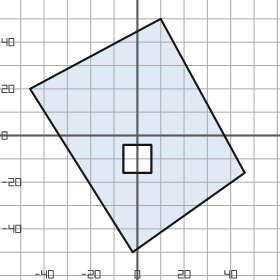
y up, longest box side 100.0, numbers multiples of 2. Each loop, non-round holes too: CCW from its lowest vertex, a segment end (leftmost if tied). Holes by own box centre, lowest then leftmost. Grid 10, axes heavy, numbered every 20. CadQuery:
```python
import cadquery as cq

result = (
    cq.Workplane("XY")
    .moveTo(-2.0, -50.0)
    .lineTo(46.0, -16.0)
    .lineTo(10.0, 50.0)
    .lineTo(-46.0, 20.0)
    .close()
    .moveTo(-6.0, -16.0)
    .lineTo(6.0, -16.0)
    .lineTo(6.0, -4.0)
    .lineTo(-6.0, -4.0)
    .close()
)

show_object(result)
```